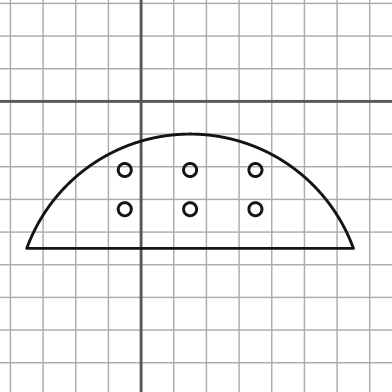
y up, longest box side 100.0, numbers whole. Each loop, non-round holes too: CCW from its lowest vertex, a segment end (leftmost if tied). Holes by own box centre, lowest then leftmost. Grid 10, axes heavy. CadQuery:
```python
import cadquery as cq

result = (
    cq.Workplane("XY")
    .moveTo(-35.0, -45.0)
    .lineTo(65.0, -45.0)
    .threePointArc((15.0, -10.0), (-35.0, -45.0))
    .close()
    .moveTo(-5.0, -33.0)
    .circle(2.0)
    .moveTo(15.0, -33.0)
    .circle(2.0)
    .moveTo(35.0, -33.0)
    .circle(2.0)
    .moveTo(-5.0, -21.0)
    .circle(2.0)
    .moveTo(15.0, -21.0)
    .circle(2.0)
    .moveTo(35.0, -21.0)
    .circle(2.0)
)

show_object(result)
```